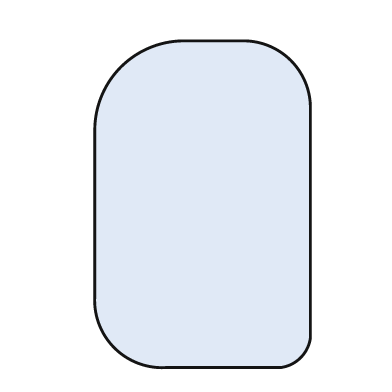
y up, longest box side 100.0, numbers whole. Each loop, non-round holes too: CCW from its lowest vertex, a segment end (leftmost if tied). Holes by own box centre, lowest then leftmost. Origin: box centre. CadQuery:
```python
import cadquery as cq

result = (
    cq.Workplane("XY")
    .moveTo(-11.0, -50.0)
    .lineTo(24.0, -50.0)
    .threePointArc((30.0, -47.0), (33.0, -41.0))
    .lineTo(33.0, 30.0)
    .threePointArc((27.0, 44.0), (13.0, 50.0))
    .lineTo(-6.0, 50.0)
    .threePointArc((-25.0, 42.0), (-33.0, 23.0))
    .lineTo(-33.0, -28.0)
    .threePointArc((-27.0, -44.0), (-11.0, -50.0))
    .close()
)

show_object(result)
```